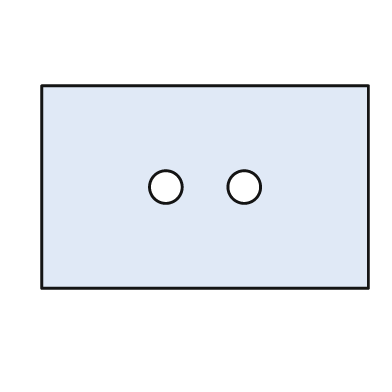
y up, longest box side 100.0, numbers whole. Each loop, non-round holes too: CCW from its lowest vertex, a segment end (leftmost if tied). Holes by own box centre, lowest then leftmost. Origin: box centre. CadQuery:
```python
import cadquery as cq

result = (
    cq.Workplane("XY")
    .moveTo(-50.0, -31.0)
    .lineTo(50.0, -31.0)
    .lineTo(50.0, 31.0)
    .lineTo(-50.0, 31.0)
    .close()
    .moveTo(-12.0, 0.0)
    .circle(5.0)
    .moveTo(12.0, 0.0)
    .circle(5.0)
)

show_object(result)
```